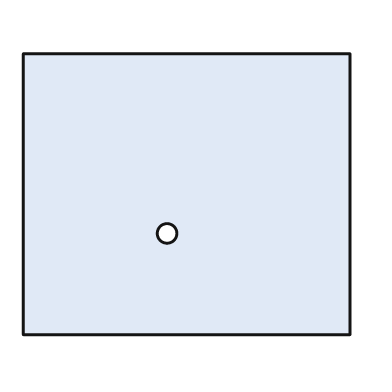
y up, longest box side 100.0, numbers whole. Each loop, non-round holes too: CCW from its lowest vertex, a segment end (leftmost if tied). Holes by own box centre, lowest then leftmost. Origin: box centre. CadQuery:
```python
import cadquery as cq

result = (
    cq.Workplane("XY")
    .moveTo(-50.0, -43.0)
    .lineTo(50.0, -43.0)
    .lineTo(50.0, 43.0)
    .lineTo(-50.0, 43.0)
    .close()
    .moveTo(-6.0, -12.0)
    .circle(3.0)
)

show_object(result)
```